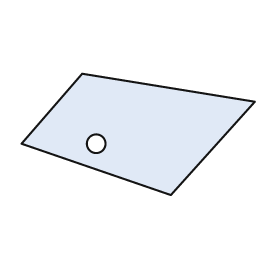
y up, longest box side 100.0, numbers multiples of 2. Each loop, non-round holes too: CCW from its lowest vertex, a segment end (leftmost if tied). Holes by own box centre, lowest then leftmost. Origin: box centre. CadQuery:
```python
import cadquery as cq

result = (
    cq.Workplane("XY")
    .moveTo(14.0, -26.0)
    .lineTo(50.0, 14.0)
    .lineTo(-24.0, 26.0)
    .lineTo(-50.0, -4.0)
    .close()
    .moveTo(-18.0, -4.0)
    .circle(4.0)
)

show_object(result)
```